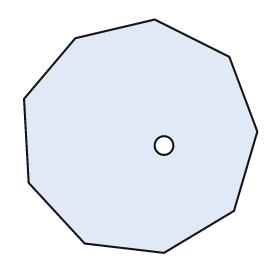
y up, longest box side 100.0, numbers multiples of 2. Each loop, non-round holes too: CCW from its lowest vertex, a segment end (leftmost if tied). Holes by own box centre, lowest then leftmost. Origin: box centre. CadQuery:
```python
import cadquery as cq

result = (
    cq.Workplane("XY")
    .moveTo(10.0, -50.0)
    .lineTo(40.0, -32.0)
    .lineTo(50.0, 2.0)
    .lineTo(38.0, 34.0)
    .lineTo(6.0, 50.0)
    .lineTo(-28.0, 42.0)
    .lineTo(-50.0, 16.0)
    .lineTo(-48.0, -20.0)
    .lineTo(-24.0, -46.0)
    .close()
    .moveTo(10.0, -4.0)
    .circle(4.0)
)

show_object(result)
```